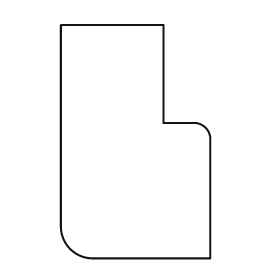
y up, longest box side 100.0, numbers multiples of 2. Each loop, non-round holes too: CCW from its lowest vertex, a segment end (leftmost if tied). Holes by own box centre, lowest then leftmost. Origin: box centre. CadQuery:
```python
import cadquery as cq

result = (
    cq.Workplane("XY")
    .moveTo(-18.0, -50.0)
    .lineTo(32.0, -50.0)
    .lineTo(32.0, 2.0)
    .threePointArc((30.0, 6.0), (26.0, 8.0))
    .lineTo(12.0, 8.0)
    .lineTo(12.0, 50.0)
    .lineTo(-32.0, 50.0)
    .lineTo(-32.0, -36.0)
    .threePointArc((-28.0, -46.0), (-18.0, -50.0))
    .close()
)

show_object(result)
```